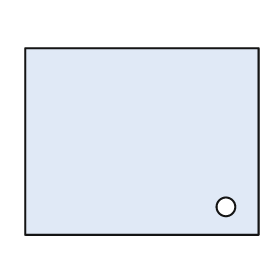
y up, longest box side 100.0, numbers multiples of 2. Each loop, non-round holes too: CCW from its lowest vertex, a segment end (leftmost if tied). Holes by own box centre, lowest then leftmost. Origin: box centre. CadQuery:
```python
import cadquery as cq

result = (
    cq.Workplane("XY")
    .moveTo(-50.0, -40.0)
    .lineTo(50.0, -40.0)
    .lineTo(50.0, 40.0)
    .lineTo(-50.0, 40.0)
    .close()
    .moveTo(36.0, -28.0)
    .circle(4.0)
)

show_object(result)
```